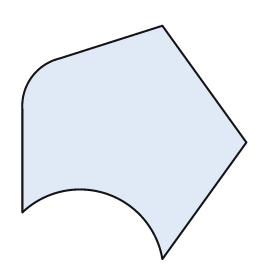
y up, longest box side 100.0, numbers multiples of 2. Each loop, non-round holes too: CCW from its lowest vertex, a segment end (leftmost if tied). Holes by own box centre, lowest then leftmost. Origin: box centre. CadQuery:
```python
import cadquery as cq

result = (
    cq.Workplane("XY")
    .moveTo(12.0, -50.0)
    .lineTo(48.0, 0.0)
    .lineTo(12.0, 50.0)
    .lineTo(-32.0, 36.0)
    .threePointArc((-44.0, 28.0), (-48.0, 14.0))
    .lineTo(-48.0, -30.0)
    .threePointArc((-12.0, -22.0), (12.0, -50.0))
    .close()
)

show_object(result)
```